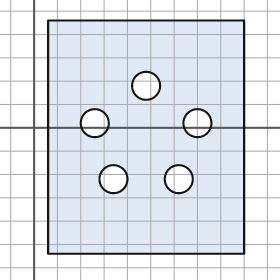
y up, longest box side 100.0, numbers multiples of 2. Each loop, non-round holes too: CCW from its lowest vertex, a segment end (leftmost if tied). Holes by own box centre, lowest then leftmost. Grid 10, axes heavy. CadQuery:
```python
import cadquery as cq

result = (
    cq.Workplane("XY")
    .moveTo(6.0, -54.0)
    .lineTo(90.0, -54.0)
    .lineTo(90.0, 46.0)
    .lineTo(6.0, 46.0)
    .close()
    .moveTo(34.0, -22.0)
    .circle(6.0)
    .moveTo(62.0, -22.0)
    .circle(6.0)
    .moveTo(26.0, 2.0)
    .circle(6.0)
    .moveTo(70.0, 2.0)
    .circle(6.0)
    .moveTo(48.0, 18.0)
    .circle(6.0)
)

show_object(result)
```